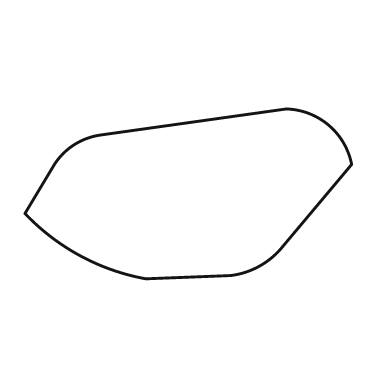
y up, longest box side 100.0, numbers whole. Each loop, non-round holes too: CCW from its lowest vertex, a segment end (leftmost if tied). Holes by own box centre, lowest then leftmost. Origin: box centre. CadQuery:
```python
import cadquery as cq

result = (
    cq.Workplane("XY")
    .moveTo(-13.0, -26.0)
    .lineTo(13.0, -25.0)
    .threePointArc((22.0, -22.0), (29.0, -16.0))
    .lineTo(50.0, 9.0)
    .threePointArc((43.0, 21.0), (30.0, 26.0))
    .lineTo(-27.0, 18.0)
    .threePointArc((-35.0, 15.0), (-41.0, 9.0))
    .lineTo(-50.0, -6.0)
    .threePointArc((-33.0, -19.0), (-13.0, -26.0))
    .close()
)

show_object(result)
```